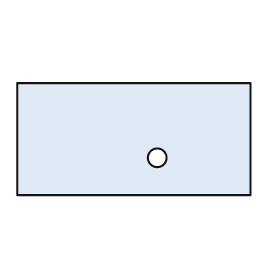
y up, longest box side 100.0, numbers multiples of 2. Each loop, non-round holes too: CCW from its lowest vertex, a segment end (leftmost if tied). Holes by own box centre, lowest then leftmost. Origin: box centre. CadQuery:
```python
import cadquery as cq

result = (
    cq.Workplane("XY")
    .moveTo(-50.0, -24.0)
    .lineTo(50.0, -24.0)
    .lineTo(50.0, 24.0)
    .lineTo(-50.0, 24.0)
    .close()
    .moveTo(10.0, -8.0)
    .circle(4.0)
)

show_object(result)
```